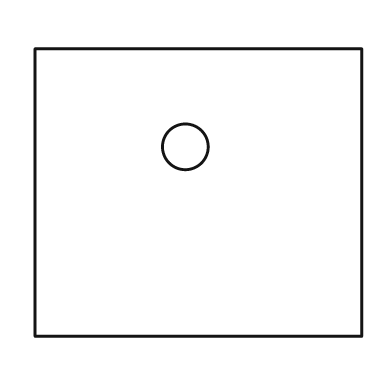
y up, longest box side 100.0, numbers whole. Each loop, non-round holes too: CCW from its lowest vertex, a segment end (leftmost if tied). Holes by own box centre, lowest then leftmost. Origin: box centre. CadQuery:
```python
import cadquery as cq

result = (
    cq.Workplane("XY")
    .moveTo(-50.0, -44.0)
    .lineTo(50.0, -44.0)
    .lineTo(50.0, 44.0)
    .lineTo(-50.0, 44.0)
    .close()
    .moveTo(-4.0, 14.0)
    .circle(7.0)
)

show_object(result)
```